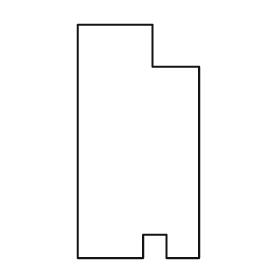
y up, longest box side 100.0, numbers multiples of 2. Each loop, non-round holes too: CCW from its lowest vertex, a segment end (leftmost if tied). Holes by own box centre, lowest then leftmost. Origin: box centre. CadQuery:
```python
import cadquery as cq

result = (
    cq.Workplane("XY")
    .moveTo(-26.0, -50.0)
    .lineTo(2.0, -50.0)
    .lineTo(2.0, -40.0)
    .lineTo(12.0, -40.0)
    .lineTo(12.0, -50.0)
    .lineTo(26.0, -50.0)
    .lineTo(26.0, 32.0)
    .lineTo(6.0, 32.0)
    .lineTo(6.0, 50.0)
    .lineTo(-26.0, 50.0)
    .close()
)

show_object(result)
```